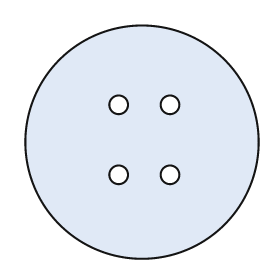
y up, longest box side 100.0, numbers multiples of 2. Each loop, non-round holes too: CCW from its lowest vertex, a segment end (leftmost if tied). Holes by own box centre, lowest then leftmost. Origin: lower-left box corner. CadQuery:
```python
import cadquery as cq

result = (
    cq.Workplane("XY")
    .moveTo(50.0, 50.0)
    .circle(50.0)
    .moveTo(40.0, 36.0)
    .circle(4.0)
    .moveTo(62.0, 36.0)
    .circle(4.0)
    .moveTo(40.0, 66.0)
    .circle(4.0)
    .moveTo(62.0, 66.0)
    .circle(4.0)
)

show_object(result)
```